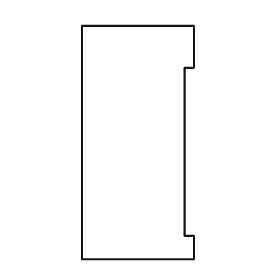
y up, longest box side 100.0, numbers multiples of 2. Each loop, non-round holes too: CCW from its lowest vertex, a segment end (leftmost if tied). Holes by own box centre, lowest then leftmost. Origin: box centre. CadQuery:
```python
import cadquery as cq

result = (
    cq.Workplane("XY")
    .moveTo(-24.0, -50.0)
    .lineTo(24.0, -50.0)
    .lineTo(24.0, -40.0)
    .lineTo(20.0, -40.0)
    .lineTo(20.0, 32.0)
    .lineTo(24.0, 32.0)
    .lineTo(24.0, 50.0)
    .lineTo(-24.0, 50.0)
    .close()
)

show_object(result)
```